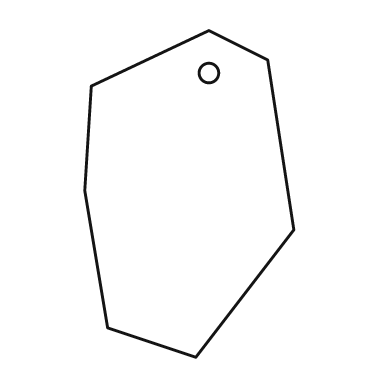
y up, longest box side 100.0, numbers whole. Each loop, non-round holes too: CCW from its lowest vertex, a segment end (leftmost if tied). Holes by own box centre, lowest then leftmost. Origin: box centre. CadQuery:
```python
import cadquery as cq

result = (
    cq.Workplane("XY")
    .moveTo(2.0, -50.0)
    .lineTo(32.0, -11.0)
    .lineTo(24.0, 41.0)
    .lineTo(6.0, 50.0)
    .lineTo(-30.0, 33.0)
    .lineTo(-32.0, 1.0)
    .lineTo(-25.0, -41.0)
    .close()
    .moveTo(6.0, 37.0)
    .circle(3.0)
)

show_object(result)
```